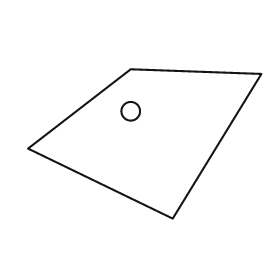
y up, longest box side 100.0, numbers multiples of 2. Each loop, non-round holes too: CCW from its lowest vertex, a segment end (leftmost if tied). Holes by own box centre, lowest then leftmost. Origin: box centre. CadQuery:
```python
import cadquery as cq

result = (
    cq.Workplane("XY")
    .moveTo(12.0, -32.0)
    .lineTo(50.0, 30.0)
    .lineTo(-6.0, 32.0)
    .lineTo(-50.0, -2.0)
    .close()
    .moveTo(-6.0, 14.0)
    .circle(4.0)
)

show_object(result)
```